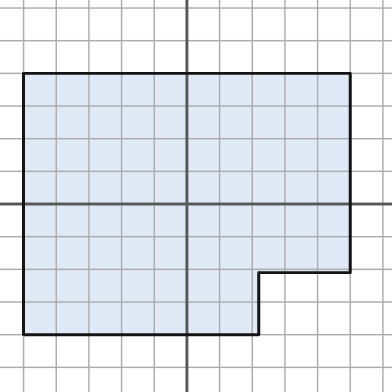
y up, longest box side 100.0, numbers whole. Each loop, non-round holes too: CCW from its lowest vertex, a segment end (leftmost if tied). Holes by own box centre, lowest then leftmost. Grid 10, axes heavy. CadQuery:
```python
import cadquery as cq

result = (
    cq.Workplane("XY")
    .moveTo(-50.0, -40.0)
    .lineTo(22.0, -40.0)
    .lineTo(22.0, -21.0)
    .lineTo(50.0, -21.0)
    .lineTo(50.0, 40.0)
    .lineTo(-50.0, 40.0)
    .close()
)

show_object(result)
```